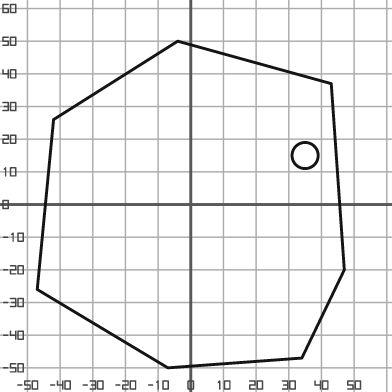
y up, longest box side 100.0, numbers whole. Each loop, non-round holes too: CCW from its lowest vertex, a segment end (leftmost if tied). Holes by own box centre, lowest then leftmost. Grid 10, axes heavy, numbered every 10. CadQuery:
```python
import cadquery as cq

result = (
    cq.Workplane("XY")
    .moveTo(-7.0, -50.0)
    .lineTo(34.0, -47.0)
    .lineTo(47.0, -20.0)
    .lineTo(43.0, 37.0)
    .lineTo(-4.0, 50.0)
    .lineTo(-42.0, 26.0)
    .lineTo(-47.0, -26.0)
    .close()
    .moveTo(35.0, 15.0)
    .circle(4.0)
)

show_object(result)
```